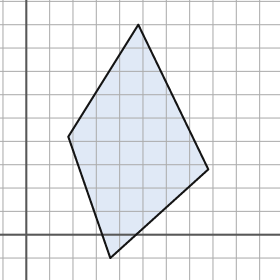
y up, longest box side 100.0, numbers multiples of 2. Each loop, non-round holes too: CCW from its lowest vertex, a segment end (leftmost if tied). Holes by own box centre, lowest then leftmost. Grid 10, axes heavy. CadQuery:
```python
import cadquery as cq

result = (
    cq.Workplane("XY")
    .moveTo(36.0, -10.0)
    .lineTo(78.0, 28.0)
    .lineTo(48.0, 90.0)
    .lineTo(18.0, 42.0)
    .close()
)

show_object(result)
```